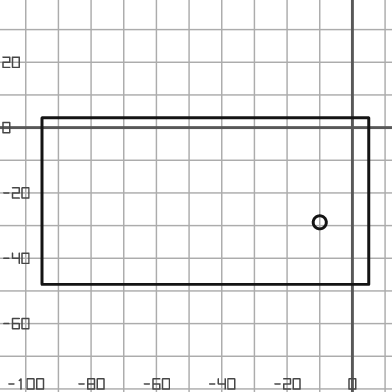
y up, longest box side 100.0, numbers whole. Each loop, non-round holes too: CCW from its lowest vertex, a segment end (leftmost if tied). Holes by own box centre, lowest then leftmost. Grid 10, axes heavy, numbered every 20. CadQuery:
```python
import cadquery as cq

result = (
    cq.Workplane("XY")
    .moveTo(-95.0, -48.0)
    .lineTo(5.0, -48.0)
    .lineTo(5.0, 3.0)
    .lineTo(-95.0, 3.0)
    .close()
    .moveTo(-10.0, -29.0)
    .circle(2.0)
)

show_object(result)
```